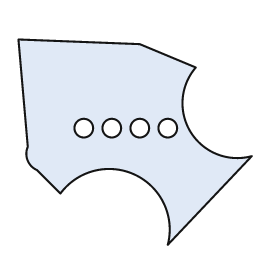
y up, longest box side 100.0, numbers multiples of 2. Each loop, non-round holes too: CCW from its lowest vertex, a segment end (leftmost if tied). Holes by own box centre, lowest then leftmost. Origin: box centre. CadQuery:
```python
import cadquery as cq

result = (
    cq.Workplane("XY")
    .moveTo(14.0, -44.0)
    .lineTo(50.0, -6.0)
    .threePointArc((24.0, 4.0), (26.0, 32.0))
    .lineTo(2.0, 42.0)
    .lineTo(-50.0, 44.0)
    .lineTo(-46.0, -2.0)
    .threePointArc((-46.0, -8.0), (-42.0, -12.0))
    .lineTo(-32.0, -22.0)
    .threePointArc((0.0, -14.0), (14.0, -44.0))
    .close()
    .moveTo(-22.0, 6.0)
    .circle(4.0)
    .moveTo(-10.0, 6.0)
    .circle(4.0)
    .moveTo(2.0, 6.0)
    .circle(4.0)
    .moveTo(14.0, 6.0)
    .circle(4.0)
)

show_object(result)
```